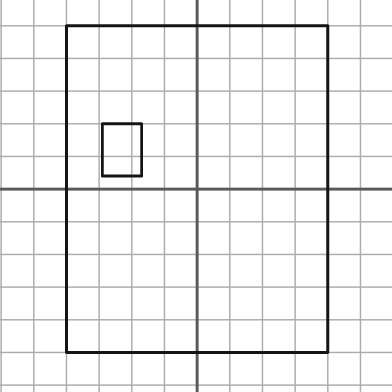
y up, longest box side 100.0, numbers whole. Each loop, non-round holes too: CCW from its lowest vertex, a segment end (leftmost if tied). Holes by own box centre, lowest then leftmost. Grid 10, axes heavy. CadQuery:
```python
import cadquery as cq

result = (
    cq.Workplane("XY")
    .moveTo(-40.0, -50.0)
    .lineTo(40.0, -50.0)
    .lineTo(40.0, 50.0)
    .lineTo(-40.0, 50.0)
    .close()
    .moveTo(-29.0, 4.0)
    .lineTo(-17.0, 4.0)
    .lineTo(-17.0, 20.0)
    .lineTo(-29.0, 20.0)
    .close()
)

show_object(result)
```